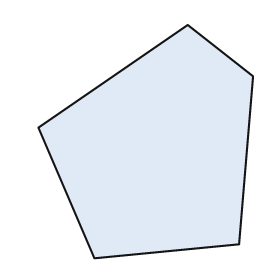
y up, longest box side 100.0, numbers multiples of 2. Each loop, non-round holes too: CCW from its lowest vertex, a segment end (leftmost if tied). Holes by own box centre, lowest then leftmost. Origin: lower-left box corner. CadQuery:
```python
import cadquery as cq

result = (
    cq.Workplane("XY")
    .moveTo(24.0, 0.0)
    .lineTo(86.0, 6.0)
    .lineTo(92.0, 78.0)
    .lineTo(64.0, 100.0)
    .lineTo(0.0, 56.0)
    .close()
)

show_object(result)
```